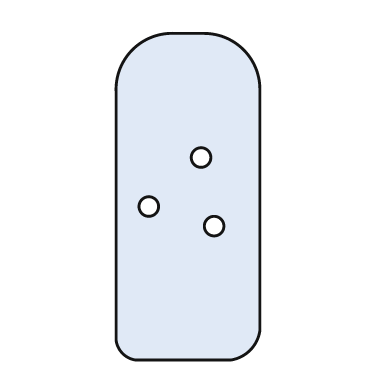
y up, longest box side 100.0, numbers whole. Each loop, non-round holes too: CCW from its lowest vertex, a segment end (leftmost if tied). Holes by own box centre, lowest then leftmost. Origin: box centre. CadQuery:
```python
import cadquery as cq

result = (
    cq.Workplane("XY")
    .moveTo(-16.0, -50.0)
    .lineTo(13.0, -50.0)
    .threePointArc((19.0, -47.0), (22.0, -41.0))
    .lineTo(22.0, 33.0)
    .threePointArc((17.0, 45.0), (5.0, 50.0))
    .lineTo(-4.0, 50.0)
    .threePointArc((-17.0, 45.0), (-22.0, 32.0))
    .lineTo(-22.0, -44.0)
    .threePointArc((-20.0, -48.0), (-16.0, -50.0))
    .close()
    .moveTo(8.0, -9.0)
    .circle(3.0)
    .moveTo(-12.0, -3.0)
    .circle(3.0)
    .moveTo(4.0, 12.0)
    .circle(3.0)
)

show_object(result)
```